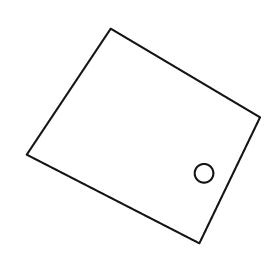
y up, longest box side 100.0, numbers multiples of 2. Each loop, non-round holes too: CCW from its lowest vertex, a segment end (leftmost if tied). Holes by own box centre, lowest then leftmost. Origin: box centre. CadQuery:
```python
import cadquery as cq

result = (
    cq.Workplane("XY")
    .moveTo(24.0, -46.0)
    .lineTo(50.0, 8.0)
    .lineTo(-14.0, 46.0)
    .lineTo(-50.0, -8.0)
    .close()
    .moveTo(26.0, -16.0)
    .circle(4.0)
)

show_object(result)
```